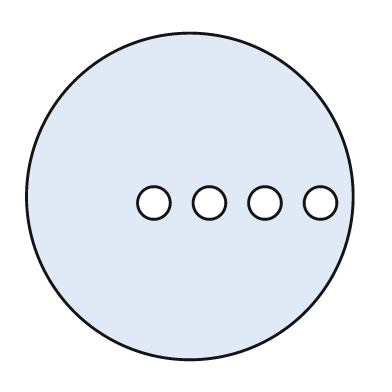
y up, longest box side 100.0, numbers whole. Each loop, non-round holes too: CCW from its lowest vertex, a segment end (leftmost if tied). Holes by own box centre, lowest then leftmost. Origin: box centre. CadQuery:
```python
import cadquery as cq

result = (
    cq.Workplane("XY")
    .moveTo(0.0, 0.0)
    .circle(50.0)
    .moveTo(-11.0, -2.0)
    .circle(5.0)
    .moveTo(6.0, -2.0)
    .circle(5.0)
    .moveTo(23.0, -2.0)
    .circle(5.0)
    .moveTo(40.0, -2.0)
    .circle(5.0)
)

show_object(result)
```